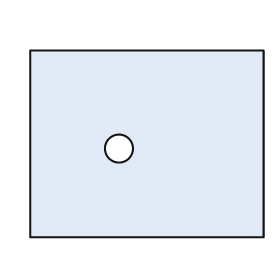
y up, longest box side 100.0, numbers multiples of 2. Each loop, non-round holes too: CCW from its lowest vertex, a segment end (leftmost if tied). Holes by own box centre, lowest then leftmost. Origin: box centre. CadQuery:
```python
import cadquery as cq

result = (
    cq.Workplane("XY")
    .moveTo(-50.0, -40.0)
    .lineTo(50.0, -40.0)
    .lineTo(50.0, 40.0)
    .lineTo(-50.0, 40.0)
    .close()
    .moveTo(-12.0, -2.0)
    .circle(6.0)
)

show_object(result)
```